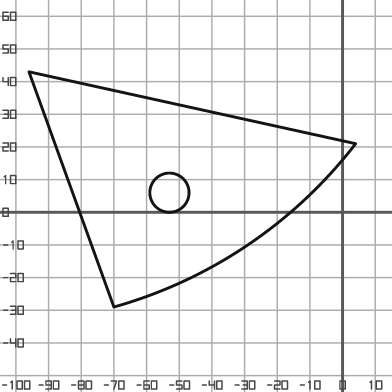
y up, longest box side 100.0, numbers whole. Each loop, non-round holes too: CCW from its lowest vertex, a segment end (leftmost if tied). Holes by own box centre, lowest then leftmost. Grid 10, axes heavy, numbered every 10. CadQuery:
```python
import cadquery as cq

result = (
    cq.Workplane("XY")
    .moveTo(-70.0, -29.0)
    .threePointArc((-29.0, -10.0), (4.0, 21.0))
    .lineTo(-96.0, 43.0)
    .close()
    .moveTo(-53.0, 6.0)
    .circle(6.0)
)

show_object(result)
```